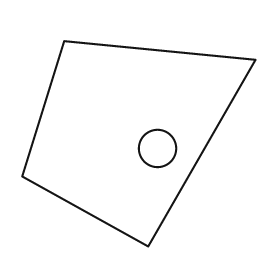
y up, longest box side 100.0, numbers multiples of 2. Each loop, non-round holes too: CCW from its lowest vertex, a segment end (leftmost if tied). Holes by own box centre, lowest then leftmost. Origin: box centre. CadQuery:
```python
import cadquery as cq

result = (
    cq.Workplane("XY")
    .moveTo(4.0, -44.0)
    .lineTo(50.0, 36.0)
    .lineTo(-32.0, 44.0)
    .lineTo(-50.0, -14.0)
    .close()
    .moveTo(8.0, -2.0)
    .circle(8.0)
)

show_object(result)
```